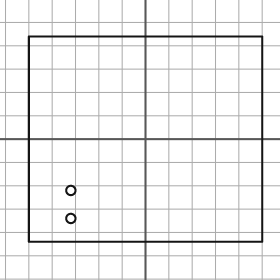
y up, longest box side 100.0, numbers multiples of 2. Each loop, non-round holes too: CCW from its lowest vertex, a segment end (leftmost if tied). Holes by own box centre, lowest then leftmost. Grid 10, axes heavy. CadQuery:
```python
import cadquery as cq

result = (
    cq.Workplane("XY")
    .moveTo(-50.0, -44.0)
    .lineTo(50.0, -44.0)
    .lineTo(50.0, 44.0)
    .lineTo(-50.0, 44.0)
    .close()
    .moveTo(-32.0, -34.0)
    .circle(2.0)
    .moveTo(-32.0, -22.0)
    .circle(2.0)
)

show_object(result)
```